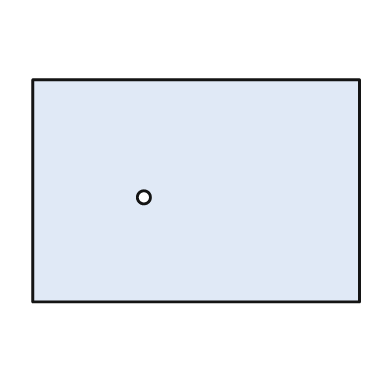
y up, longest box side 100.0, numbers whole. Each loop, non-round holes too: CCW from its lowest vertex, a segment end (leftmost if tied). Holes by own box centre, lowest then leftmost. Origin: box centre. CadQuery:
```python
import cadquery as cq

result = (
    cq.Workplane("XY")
    .moveTo(-50.0, -34.0)
    .lineTo(50.0, -34.0)
    .lineTo(50.0, 34.0)
    .lineTo(-50.0, 34.0)
    .close()
    .moveTo(-16.0, -2.0)
    .circle(2.0)
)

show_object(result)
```